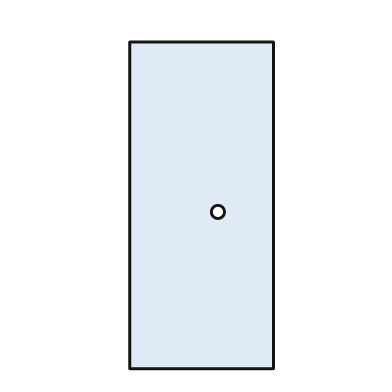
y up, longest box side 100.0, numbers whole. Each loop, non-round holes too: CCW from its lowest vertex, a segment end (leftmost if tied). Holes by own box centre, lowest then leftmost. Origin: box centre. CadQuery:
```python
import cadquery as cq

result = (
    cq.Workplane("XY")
    .moveTo(-22.0, -50.0)
    .lineTo(22.0, -50.0)
    .lineTo(22.0, 50.0)
    .lineTo(-22.0, 50.0)
    .close()
    .moveTo(5.0, -2.0)
    .circle(2.0)
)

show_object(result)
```